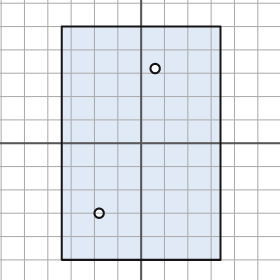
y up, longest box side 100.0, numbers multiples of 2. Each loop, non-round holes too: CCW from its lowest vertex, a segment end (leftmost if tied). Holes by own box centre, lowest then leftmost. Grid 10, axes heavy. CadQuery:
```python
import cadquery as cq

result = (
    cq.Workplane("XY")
    .moveTo(-34.0, -50.0)
    .lineTo(34.0, -50.0)
    .lineTo(34.0, 50.0)
    .lineTo(-34.0, 50.0)
    .close()
    .moveTo(-18.0, -30.0)
    .circle(2.0)
    .moveTo(6.0, 32.0)
    .circle(2.0)
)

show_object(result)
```